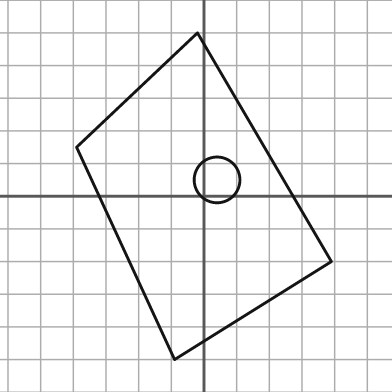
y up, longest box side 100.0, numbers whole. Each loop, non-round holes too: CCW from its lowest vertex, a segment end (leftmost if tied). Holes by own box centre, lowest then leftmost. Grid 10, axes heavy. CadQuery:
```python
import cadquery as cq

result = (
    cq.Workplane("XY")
    .moveTo(-9.0, -50.0)
    .lineTo(39.0, -20.0)
    .lineTo(-2.0, 50.0)
    .lineTo(-39.0, 15.0)
    .close()
    .moveTo(4.0, 5.0)
    .circle(7.0)
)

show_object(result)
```